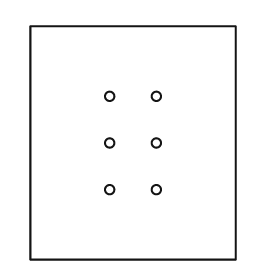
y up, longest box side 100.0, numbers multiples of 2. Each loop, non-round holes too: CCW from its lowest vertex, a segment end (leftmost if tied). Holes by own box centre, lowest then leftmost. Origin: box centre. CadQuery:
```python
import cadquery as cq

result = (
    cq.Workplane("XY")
    .moveTo(-44.0, -50.0)
    .lineTo(44.0, -50.0)
    .lineTo(44.0, 50.0)
    .lineTo(-44.0, 50.0)
    .close()
    .moveTo(-10.0, -20.0)
    .circle(2.0)
    .moveTo(10.0, -20.0)
    .circle(2.0)
    .moveTo(-10.0, 0.0)
    .circle(2.0)
    .moveTo(10.0, 0.0)
    .circle(2.0)
    .moveTo(-10.0, 20.0)
    .circle(2.0)
    .moveTo(10.0, 20.0)
    .circle(2.0)
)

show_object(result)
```